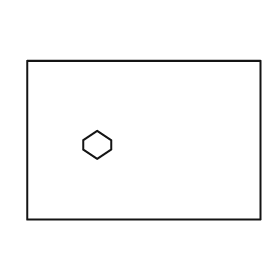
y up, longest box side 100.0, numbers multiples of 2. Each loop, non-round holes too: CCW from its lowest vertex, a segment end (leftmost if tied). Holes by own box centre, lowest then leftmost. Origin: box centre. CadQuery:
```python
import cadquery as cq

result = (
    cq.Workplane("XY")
    .moveTo(-50.0, -34.0)
    .lineTo(50.0, -34.0)
    .lineTo(50.0, 34.0)
    .lineTo(-50.0, 34.0)
    .close()
    .moveTo(-20.0, -8.0)
    .lineTo(-14.0, -4.0)
    .lineTo(-14.0, 0.0)
    .lineTo(-20.0, 4.0)
    .lineTo(-26.0, 0.0)
    .lineTo(-26.0, -4.0)
    .close()
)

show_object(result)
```